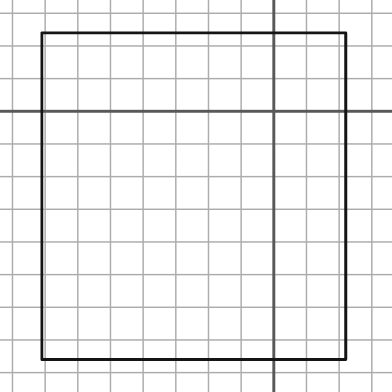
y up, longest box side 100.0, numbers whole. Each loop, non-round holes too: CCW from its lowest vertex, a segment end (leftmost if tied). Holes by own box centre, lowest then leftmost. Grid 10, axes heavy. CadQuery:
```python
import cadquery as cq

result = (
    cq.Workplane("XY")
    .moveTo(-71.0, -76.0)
    .lineTo(22.0, -76.0)
    .lineTo(22.0, 24.0)
    .lineTo(-71.0, 24.0)
    .close()
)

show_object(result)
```